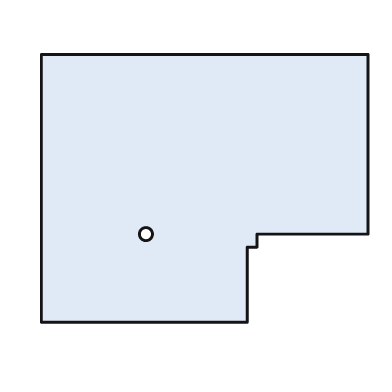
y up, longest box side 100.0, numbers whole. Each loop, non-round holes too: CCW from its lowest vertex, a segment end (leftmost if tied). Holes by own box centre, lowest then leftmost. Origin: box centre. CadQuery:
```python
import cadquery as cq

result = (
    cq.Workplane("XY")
    .moveTo(-50.0, -41.0)
    .lineTo(13.0, -41.0)
    .lineTo(13.0, -18.0)
    .lineTo(16.0, -18.0)
    .lineTo(16.0, -14.0)
    .lineTo(50.0, -14.0)
    .lineTo(50.0, 41.0)
    .lineTo(-50.0, 41.0)
    .close()
    .moveTo(-18.0, -14.0)
    .circle(2.0)
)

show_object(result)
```